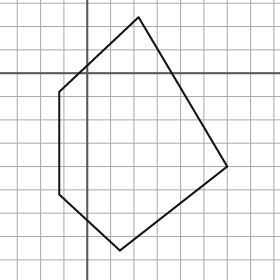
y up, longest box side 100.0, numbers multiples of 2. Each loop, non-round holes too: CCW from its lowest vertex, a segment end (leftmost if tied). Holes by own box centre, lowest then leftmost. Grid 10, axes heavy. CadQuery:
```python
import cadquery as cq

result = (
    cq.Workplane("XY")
    .moveTo(14.0, -76.0)
    .lineTo(60.0, -40.0)
    .lineTo(22.0, 24.0)
    .lineTo(-12.0, -8.0)
    .lineTo(-12.0, -52.0)
    .close()
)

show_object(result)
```